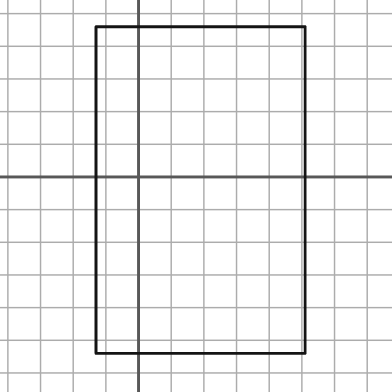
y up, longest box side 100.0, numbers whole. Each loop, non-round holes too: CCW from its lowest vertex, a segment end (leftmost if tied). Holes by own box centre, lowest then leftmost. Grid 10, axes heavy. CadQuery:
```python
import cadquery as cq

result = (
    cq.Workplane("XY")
    .moveTo(-13.0, -54.0)
    .lineTo(51.0, -54.0)
    .lineTo(51.0, 46.0)
    .lineTo(-13.0, 46.0)
    .close()
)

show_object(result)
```